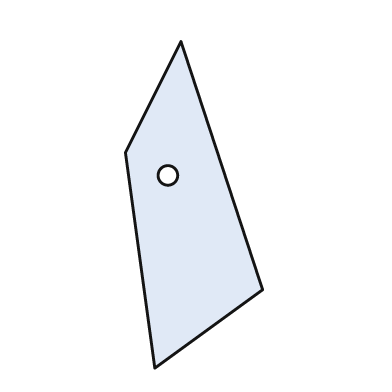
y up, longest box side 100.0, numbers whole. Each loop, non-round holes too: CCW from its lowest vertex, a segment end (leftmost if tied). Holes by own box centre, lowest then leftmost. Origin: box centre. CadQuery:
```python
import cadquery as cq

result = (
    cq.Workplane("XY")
    .moveTo(-12.0, -50.0)
    .lineTo(21.0, -26.0)
    .lineTo(-4.0, 50.0)
    .lineTo(-21.0, 16.0)
    .close()
    .moveTo(-8.0, 9.0)
    .circle(3.0)
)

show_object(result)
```